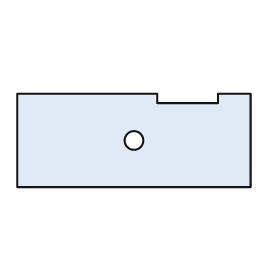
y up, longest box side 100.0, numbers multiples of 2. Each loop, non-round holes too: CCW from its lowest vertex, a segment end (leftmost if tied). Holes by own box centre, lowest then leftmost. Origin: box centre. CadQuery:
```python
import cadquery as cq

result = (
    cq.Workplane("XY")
    .moveTo(-50.0, -20.0)
    .lineTo(50.0, -20.0)
    .lineTo(50.0, 20.0)
    .lineTo(36.0, 20.0)
    .lineTo(36.0, 16.0)
    .lineTo(10.0, 16.0)
    .lineTo(10.0, 20.0)
    .lineTo(-50.0, 20.0)
    .close()
    .moveTo(0.0, 0.0)
    .circle(4.0)
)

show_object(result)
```